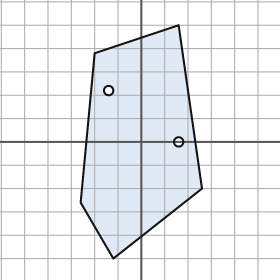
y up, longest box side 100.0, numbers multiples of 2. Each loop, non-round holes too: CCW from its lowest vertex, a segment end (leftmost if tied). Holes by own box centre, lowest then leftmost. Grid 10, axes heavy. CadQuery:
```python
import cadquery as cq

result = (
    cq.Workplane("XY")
    .moveTo(-12.0, -50.0)
    .lineTo(26.0, -20.0)
    .lineTo(16.0, 50.0)
    .lineTo(-20.0, 38.0)
    .lineTo(-26.0, -26.0)
    .close()
    .moveTo(16.0, 0.0)
    .circle(2.0)
    .moveTo(-14.0, 22.0)
    .circle(2.0)
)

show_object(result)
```